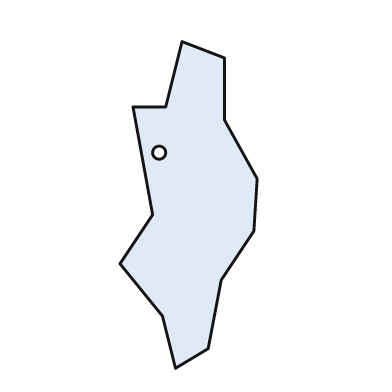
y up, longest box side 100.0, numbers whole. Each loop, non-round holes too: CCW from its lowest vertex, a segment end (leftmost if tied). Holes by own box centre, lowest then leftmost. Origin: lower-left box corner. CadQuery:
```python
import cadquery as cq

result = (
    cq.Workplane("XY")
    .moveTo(17.0, 0.0)
    .lineTo(27.0, 6.0)
    .lineTo(31.0, 27.0)
    .lineTo(41.0, 42.0)
    .lineTo(42.0, 58.0)
    .lineTo(32.0, 76.0)
    .lineTo(32.0, 95.0)
    .lineTo(19.0, 100.0)
    .lineTo(14.0, 80.0)
    .lineTo(4.0, 80.0)
    .lineTo(10.0, 47.0)
    .lineTo(0.0, 32.0)
    .lineTo(13.0, 16.0)
    .close()
    .moveTo(12.0, 66.0)
    .circle(2.0)
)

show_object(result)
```